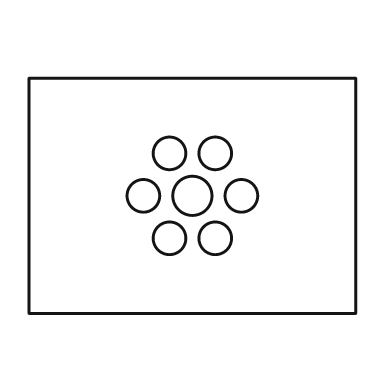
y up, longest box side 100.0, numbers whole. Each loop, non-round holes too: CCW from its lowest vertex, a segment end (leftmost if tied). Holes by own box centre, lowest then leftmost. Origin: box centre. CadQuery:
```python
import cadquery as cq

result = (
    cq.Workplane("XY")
    .moveTo(-50.0, -36.0)
    .lineTo(50.0, -36.0)
    .lineTo(50.0, 36.0)
    .lineTo(-50.0, 36.0)
    .close()
    .moveTo(-7.0, -13.0)
    .circle(5.0)
    .moveTo(7.0, -13.0)
    .circle(5.0)
    .moveTo(-15.0, 0.0)
    .circle(5.0)
    .moveTo(0.0, 0.0)
    .circle(6.0)
    .moveTo(15.0, 0.0)
    .circle(5.0)
    .moveTo(-7.0, 13.0)
    .circle(5.0)
    .moveTo(7.0, 13.0)
    .circle(5.0)
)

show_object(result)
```